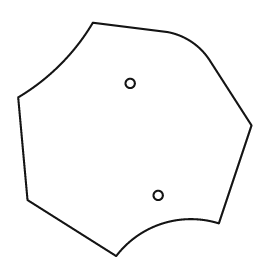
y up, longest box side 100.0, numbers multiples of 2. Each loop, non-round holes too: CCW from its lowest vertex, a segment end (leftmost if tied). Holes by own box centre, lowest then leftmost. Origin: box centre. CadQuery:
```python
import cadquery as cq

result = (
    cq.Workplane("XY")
    .moveTo(-8.0, -50.0)
    .threePointArc((12.0, -36.0), (36.0, -36.0))
    .lineTo(50.0, 6.0)
    .lineTo(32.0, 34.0)
    .threePointArc((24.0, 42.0), (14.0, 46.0))
    .lineTo(-18.0, 50.0)
    .threePointArc((-32.0, 32.0), (-50.0, 18.0))
    .lineTo(-46.0, -26.0)
    .close()
    .moveTo(10.0, -24.0)
    .circle(2.0)
    .moveTo(-2.0, 24.0)
    .circle(2.0)
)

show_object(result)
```